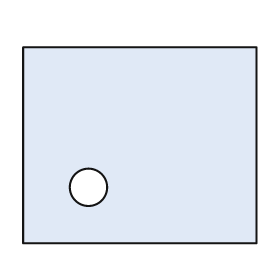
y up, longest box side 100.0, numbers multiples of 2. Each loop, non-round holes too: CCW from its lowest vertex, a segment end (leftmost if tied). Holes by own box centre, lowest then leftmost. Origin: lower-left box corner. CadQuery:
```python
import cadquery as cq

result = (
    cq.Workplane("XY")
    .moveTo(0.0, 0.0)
    .lineTo(100.0, 0.0)
    .lineTo(100.0, 84.0)
    .lineTo(0.0, 84.0)
    .close()
    .moveTo(28.0, 24.0)
    .circle(8.0)
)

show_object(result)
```